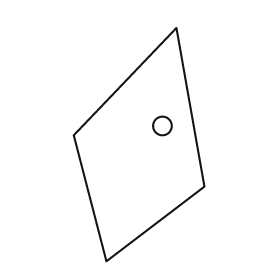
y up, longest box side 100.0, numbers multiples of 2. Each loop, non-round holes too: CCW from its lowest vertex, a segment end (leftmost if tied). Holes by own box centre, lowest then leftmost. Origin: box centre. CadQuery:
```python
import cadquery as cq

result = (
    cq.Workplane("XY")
    .moveTo(-14.0, -50.0)
    .lineTo(28.0, -18.0)
    .lineTo(16.0, 50.0)
    .lineTo(-28.0, 4.0)
    .close()
    .moveTo(10.0, 8.0)
    .circle(4.0)
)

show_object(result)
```